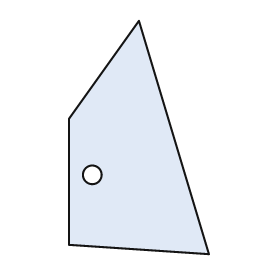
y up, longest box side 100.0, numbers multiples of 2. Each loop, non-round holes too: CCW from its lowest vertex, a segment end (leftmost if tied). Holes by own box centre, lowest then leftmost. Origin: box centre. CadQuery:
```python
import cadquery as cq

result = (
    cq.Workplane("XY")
    .moveTo(30.0, -50.0)
    .lineTo(0.0, 50.0)
    .lineTo(-30.0, 8.0)
    .lineTo(-30.0, -46.0)
    .close()
    .moveTo(-20.0, -16.0)
    .circle(4.0)
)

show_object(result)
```